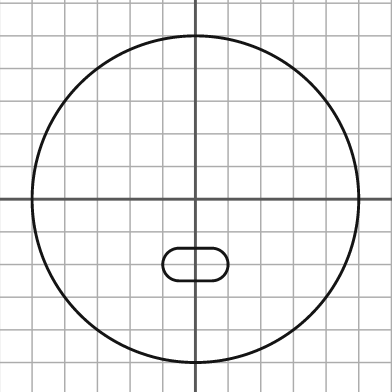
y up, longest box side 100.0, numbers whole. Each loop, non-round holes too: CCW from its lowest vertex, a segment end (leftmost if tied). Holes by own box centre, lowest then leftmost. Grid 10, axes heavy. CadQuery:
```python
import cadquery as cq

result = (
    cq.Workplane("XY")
    .moveTo(0.0, 0.0)
    .circle(50.0)
    .moveTo(-5.0, -25.0)
    .lineTo(5.0, -25.0)
    .threePointArc((10.0, -20.0), (5.0, -15.0))
    .lineTo(-5.0, -15.0)
    .threePointArc((-10.0, -20.0), (-5.0, -25.0))
    .close()
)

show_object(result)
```